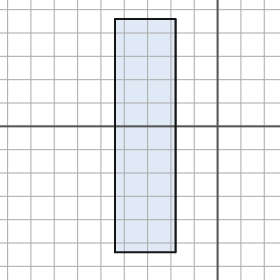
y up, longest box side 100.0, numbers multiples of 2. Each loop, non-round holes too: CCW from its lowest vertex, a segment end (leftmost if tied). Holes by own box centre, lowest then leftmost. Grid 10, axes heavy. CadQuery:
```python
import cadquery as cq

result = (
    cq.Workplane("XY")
    .moveTo(-44.0, -54.0)
    .lineTo(-18.0, -54.0)
    .lineTo(-18.0, 46.0)
    .lineTo(-44.0, 46.0)
    .close()
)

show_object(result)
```